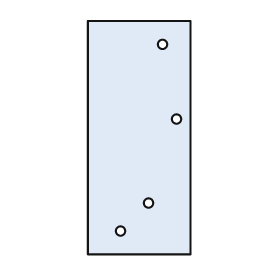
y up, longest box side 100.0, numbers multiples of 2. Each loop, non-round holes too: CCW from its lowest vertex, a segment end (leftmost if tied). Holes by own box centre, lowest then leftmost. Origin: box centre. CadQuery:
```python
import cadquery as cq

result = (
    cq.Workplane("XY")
    .moveTo(-22.0, -50.0)
    .lineTo(22.0, -50.0)
    .lineTo(22.0, 50.0)
    .lineTo(-22.0, 50.0)
    .close()
    .moveTo(-8.0, -40.0)
    .circle(2.0)
    .moveTo(4.0, -28.0)
    .circle(2.0)
    .moveTo(16.0, 8.0)
    .circle(2.0)
    .moveTo(10.0, 40.0)
    .circle(2.0)
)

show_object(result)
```